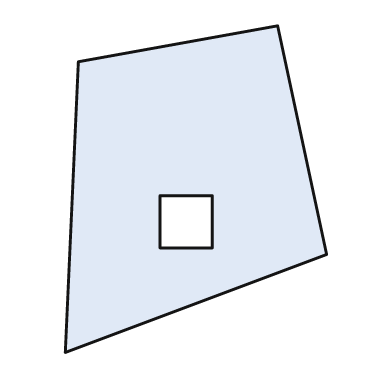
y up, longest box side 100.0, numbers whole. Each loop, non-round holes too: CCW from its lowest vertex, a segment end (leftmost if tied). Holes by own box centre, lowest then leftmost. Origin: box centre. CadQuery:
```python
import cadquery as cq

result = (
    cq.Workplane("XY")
    .moveTo(-40.0, -50.0)
    .lineTo(40.0, -20.0)
    .lineTo(25.0, 50.0)
    .lineTo(-36.0, 39.0)
    .close()
    .moveTo(-11.0, -18.0)
    .lineTo(5.0, -18.0)
    .lineTo(5.0, -2.0)
    .lineTo(-11.0, -2.0)
    .close()
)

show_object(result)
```